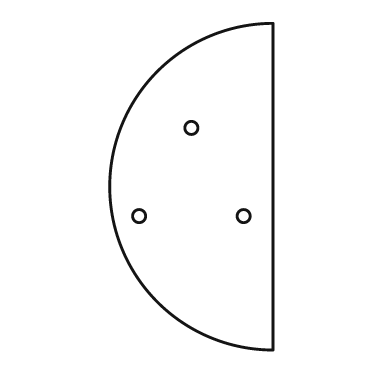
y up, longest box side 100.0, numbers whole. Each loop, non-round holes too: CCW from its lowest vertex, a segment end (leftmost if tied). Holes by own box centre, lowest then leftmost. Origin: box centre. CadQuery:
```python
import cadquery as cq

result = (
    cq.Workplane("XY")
    .moveTo(25.0, -50.0)
    .lineTo(25.0, 50.0)
    .threePointArc((-25.0, 0.0), (25.0, -50.0))
    .close()
    .moveTo(-16.0, -9.0)
    .circle(2.0)
    .moveTo(16.0, -9.0)
    .circle(2.0)
    .moveTo(0.0, 18.0)
    .circle(2.0)
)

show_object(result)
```